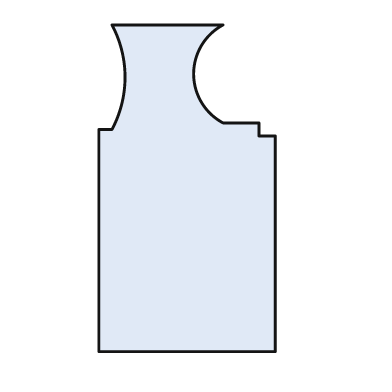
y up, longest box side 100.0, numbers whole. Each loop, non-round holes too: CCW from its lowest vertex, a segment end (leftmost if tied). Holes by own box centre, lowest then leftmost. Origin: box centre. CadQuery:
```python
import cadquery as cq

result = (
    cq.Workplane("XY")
    .moveTo(-27.0, -50.0)
    .lineTo(27.0, -50.0)
    .lineTo(27.0, 16.0)
    .lineTo(22.0, 16.0)
    .lineTo(22.0, 20.0)
    .lineTo(11.0, 20.0)
    .threePointArc((2.0, 35.0), (11.0, 50.0))
    .lineTo(-23.0, 50.0)
    .threePointArc((-19.0, 34.0), (-23.0, 18.0))
    .lineTo(-27.0, 18.0)
    .close()
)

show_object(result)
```